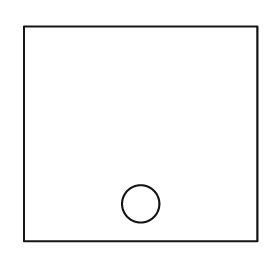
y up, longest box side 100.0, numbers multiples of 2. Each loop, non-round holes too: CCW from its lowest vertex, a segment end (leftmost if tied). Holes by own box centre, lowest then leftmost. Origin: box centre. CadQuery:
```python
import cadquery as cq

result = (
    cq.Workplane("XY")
    .moveTo(-50.0, -46.0)
    .lineTo(50.0, -46.0)
    .lineTo(50.0, 46.0)
    .lineTo(-50.0, 46.0)
    .close()
    .moveTo(0.0, -30.0)
    .circle(8.0)
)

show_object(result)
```